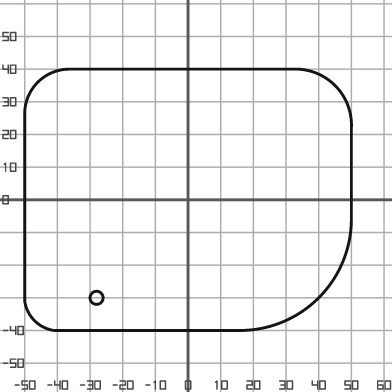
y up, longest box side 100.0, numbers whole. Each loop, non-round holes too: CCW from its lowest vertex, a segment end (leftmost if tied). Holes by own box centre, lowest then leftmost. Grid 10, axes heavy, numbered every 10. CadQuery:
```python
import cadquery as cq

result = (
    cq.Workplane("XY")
    .moveTo(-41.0, -40.0)
    .lineTo(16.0, -40.0)
    .threePointArc((40.0, -30.0), (50.0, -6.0))
    .lineTo(50.0, 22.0)
    .threePointArc((45.0, 35.0), (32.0, 40.0))
    .lineTo(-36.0, 40.0)
    .threePointArc((-46.0, 36.0), (-50.0, 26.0))
    .lineTo(-50.0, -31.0)
    .threePointArc((-47.0, -37.0), (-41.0, -40.0))
    .close()
    .moveTo(-28.0, -30.0)
    .circle(2.0)
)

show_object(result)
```